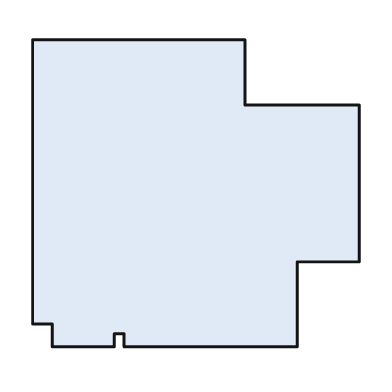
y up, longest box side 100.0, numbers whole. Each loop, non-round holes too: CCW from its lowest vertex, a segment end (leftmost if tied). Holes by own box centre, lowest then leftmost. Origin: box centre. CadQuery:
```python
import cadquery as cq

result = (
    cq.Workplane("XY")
    .moveTo(-44.0, -47.0)
    .lineTo(-25.0, -47.0)
    .lineTo(-25.0, -43.0)
    .lineTo(-22.0, -43.0)
    .lineTo(-22.0, -47.0)
    .lineTo(31.0, -47.0)
    .lineTo(31.0, -21.0)
    .lineTo(50.0, -21.0)
    .lineTo(50.0, 27.0)
    .lineTo(15.0, 27.0)
    .lineTo(15.0, 47.0)
    .lineTo(-50.0, 47.0)
    .lineTo(-50.0, -40.0)
    .lineTo(-44.0, -40.0)
    .close()
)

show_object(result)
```